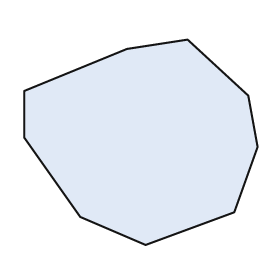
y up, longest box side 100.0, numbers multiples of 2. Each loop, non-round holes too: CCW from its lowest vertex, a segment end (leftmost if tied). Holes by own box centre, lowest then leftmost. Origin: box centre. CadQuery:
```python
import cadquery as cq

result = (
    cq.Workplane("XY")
    .moveTo(2.0, -44.0)
    .lineTo(40.0, -30.0)
    .lineTo(50.0, -2.0)
    .lineTo(46.0, 20.0)
    .lineTo(20.0, 44.0)
    .lineTo(-6.0, 40.0)
    .lineTo(-50.0, 22.0)
    .lineTo(-50.0, 2.0)
    .lineTo(-26.0, -32.0)
    .close()
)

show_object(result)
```